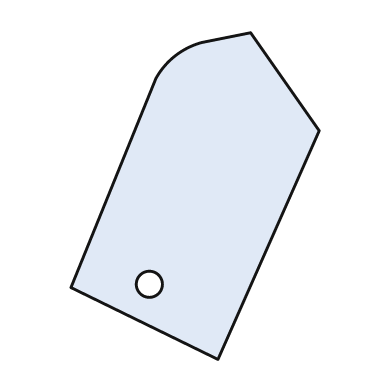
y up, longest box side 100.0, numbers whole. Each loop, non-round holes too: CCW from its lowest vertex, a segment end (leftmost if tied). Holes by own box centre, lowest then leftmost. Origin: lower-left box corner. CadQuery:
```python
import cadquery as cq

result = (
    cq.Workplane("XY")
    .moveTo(45.0, 0.0)
    .lineTo(76.0, 70.0)
    .lineTo(55.0, 100.0)
    .lineTo(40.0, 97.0)
    .threePointArc((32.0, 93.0), (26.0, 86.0))
    .lineTo(0.0, 22.0)
    .close()
    .moveTo(24.0, 23.0)
    .circle(4.0)
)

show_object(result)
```